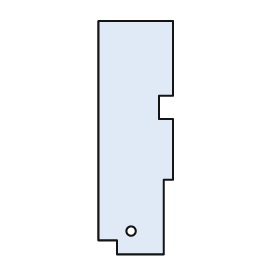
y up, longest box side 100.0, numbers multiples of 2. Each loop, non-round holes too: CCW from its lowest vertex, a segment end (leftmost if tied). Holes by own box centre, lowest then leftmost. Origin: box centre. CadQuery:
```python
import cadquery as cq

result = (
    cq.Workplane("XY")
    .moveTo(-8.0, -50.0)
    .lineTo(12.0, -50.0)
    .lineTo(12.0, -18.0)
    .lineTo(16.0, -18.0)
    .lineTo(16.0, 8.0)
    .lineTo(10.0, 8.0)
    .lineTo(10.0, 18.0)
    .lineTo(16.0, 18.0)
    .lineTo(16.0, 50.0)
    .lineTo(-16.0, 50.0)
    .lineTo(-16.0, -44.0)
    .lineTo(-8.0, -44.0)
    .close()
    .moveTo(-2.0, -40.0)
    .circle(2.0)
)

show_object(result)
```